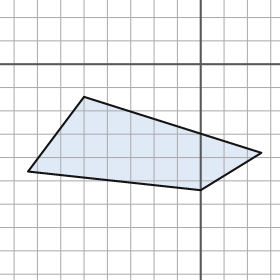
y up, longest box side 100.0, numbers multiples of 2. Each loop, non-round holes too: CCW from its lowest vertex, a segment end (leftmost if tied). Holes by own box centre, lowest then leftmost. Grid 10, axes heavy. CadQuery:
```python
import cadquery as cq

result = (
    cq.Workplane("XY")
    .moveTo(0.0, -54.0)
    .lineTo(26.0, -38.0)
    .lineTo(-50.0, -14.0)
    .lineTo(-74.0, -46.0)
    .close()
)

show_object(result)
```